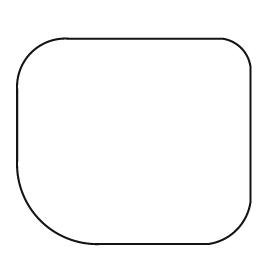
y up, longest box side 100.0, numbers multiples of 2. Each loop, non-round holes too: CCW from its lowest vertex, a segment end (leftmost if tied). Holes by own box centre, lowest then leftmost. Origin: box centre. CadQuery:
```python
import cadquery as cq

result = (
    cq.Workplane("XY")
    .moveTo(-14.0, -44.0)
    .lineTo(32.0, -44.0)
    .threePointArc((44.0, -38.0), (50.0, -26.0))
    .lineTo(50.0, 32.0)
    .threePointArc((46.0, 40.0), (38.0, 44.0))
    .lineTo(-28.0, 44.0)
    .threePointArc((-44.0, 38.0), (-50.0, 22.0))
    .lineTo(-50.0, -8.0)
    .threePointArc((-40.0, -34.0), (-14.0, -44.0))
    .close()
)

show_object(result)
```